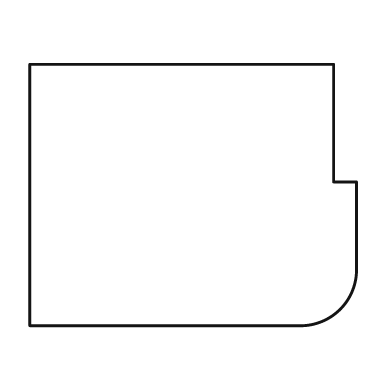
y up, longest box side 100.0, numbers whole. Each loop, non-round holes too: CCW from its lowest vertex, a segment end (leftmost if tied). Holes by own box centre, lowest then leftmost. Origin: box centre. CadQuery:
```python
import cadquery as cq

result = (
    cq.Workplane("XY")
    .moveTo(-50.0, -40.0)
    .lineTo(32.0, -40.0)
    .threePointArc((45.0, -35.0), (50.0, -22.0))
    .lineTo(50.0, 4.0)
    .lineTo(43.0, 4.0)
    .lineTo(43.0, 40.0)
    .lineTo(-50.0, 40.0)
    .close()
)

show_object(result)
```